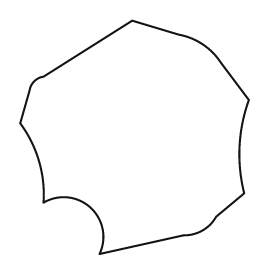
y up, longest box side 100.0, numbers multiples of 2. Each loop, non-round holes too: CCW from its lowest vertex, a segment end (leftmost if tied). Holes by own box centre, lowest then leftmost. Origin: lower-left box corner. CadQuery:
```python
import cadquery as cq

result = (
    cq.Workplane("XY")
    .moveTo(34.0, 0.0)
    .lineTo(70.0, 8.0)
    .threePointArc((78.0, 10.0), (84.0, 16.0))
    .lineTo(96.0, 26.0)
    .threePointArc((94.0, 46.0), (98.0, 66.0))
    .lineTo(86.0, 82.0)
    .threePointArc((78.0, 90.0), (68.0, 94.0))
    .lineTo(48.0, 100.0)
    .lineTo(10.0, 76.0)
    .threePointArc((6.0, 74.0), (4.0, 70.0))
    .lineTo(0.0, 56.0)
    .threePointArc((8.0, 40.0), (10.0, 22.0))
    .threePointArc((30.0, 20.0), (34.0, 0.0))
    .close()
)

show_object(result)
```